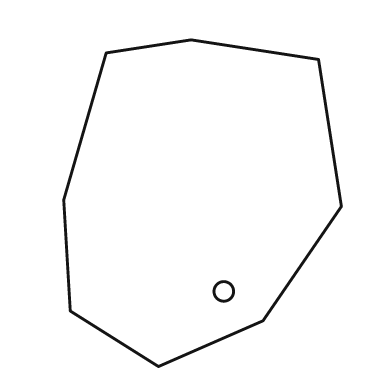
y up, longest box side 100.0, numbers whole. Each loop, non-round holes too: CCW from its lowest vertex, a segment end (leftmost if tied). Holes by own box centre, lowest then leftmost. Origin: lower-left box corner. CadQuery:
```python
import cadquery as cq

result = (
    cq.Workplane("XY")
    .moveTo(29.0, 0.0)
    .lineTo(61.0, 14.0)
    .lineTo(85.0, 49.0)
    .lineTo(78.0, 94.0)
    .lineTo(39.0, 100.0)
    .lineTo(13.0, 96.0)
    .lineTo(0.0, 51.0)
    .lineTo(2.0, 17.0)
    .close()
    .moveTo(49.0, 23.0)
    .circle(3.0)
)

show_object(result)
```